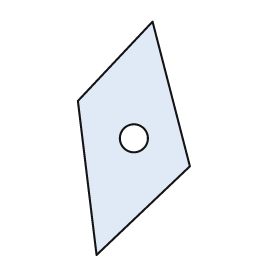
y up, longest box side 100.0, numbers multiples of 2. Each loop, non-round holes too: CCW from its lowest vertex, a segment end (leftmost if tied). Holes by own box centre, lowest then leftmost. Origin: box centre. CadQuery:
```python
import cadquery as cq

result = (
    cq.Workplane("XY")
    .moveTo(-16.0, -50.0)
    .lineTo(24.0, -12.0)
    .lineTo(8.0, 50.0)
    .lineTo(-24.0, 16.0)
    .close()
    .moveTo(0.0, 0.0)
    .circle(6.0)
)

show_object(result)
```